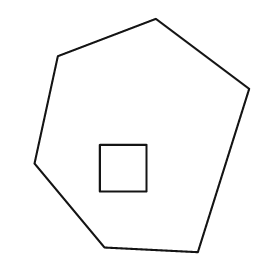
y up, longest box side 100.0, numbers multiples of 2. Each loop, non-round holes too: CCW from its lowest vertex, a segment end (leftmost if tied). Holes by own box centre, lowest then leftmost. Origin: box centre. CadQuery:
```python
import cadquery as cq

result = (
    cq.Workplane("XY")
    .moveTo(24.0, -50.0)
    .lineTo(46.0, 20.0)
    .lineTo(6.0, 50.0)
    .lineTo(-36.0, 34.0)
    .lineTo(-46.0, -12.0)
    .lineTo(-16.0, -48.0)
    .close()
    .moveTo(-18.0, -24.0)
    .lineTo(2.0, -24.0)
    .lineTo(2.0, -4.0)
    .lineTo(-18.0, -4.0)
    .close()
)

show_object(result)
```